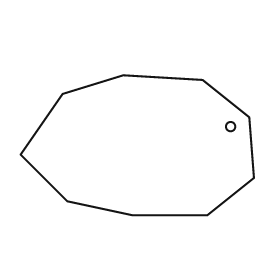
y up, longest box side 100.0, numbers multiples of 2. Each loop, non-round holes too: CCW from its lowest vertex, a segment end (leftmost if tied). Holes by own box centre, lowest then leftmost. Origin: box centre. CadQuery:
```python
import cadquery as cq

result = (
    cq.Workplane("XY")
    .moveTo(-2.0, -30.0)
    .lineTo(30.0, -30.0)
    .lineTo(50.0, -14.0)
    .lineTo(48.0, 12.0)
    .lineTo(28.0, 28.0)
    .lineTo(-6.0, 30.0)
    .lineTo(-32.0, 22.0)
    .lineTo(-50.0, -4.0)
    .lineTo(-30.0, -24.0)
    .close()
    .moveTo(40.0, 8.0)
    .circle(2.0)
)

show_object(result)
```